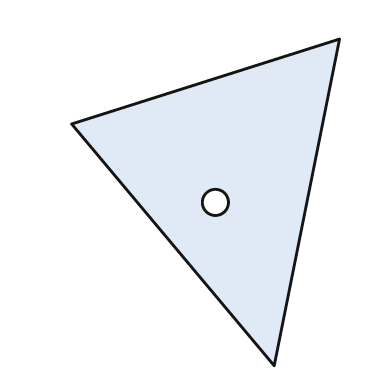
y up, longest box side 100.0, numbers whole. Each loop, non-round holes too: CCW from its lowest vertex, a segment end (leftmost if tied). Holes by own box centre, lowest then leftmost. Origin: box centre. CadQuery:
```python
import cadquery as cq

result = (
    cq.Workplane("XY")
    .moveTo(21.0, -50.0)
    .lineTo(41.0, 50.0)
    .lineTo(-41.0, 24.0)
    .close()
    .moveTo(3.0, 0.0)
    .circle(4.0)
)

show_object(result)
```